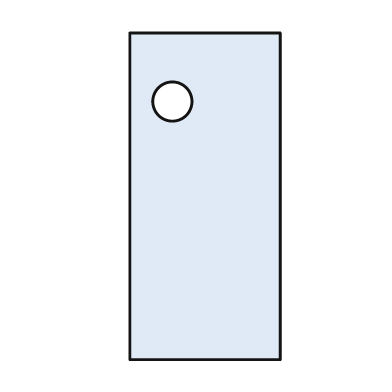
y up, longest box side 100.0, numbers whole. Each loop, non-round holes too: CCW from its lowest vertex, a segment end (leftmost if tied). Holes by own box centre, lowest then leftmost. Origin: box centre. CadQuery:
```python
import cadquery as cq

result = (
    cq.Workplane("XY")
    .moveTo(-23.0, -50.0)
    .lineTo(23.0, -50.0)
    .lineTo(23.0, 50.0)
    .lineTo(-23.0, 50.0)
    .close()
    .moveTo(-10.0, 29.0)
    .circle(6.0)
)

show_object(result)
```